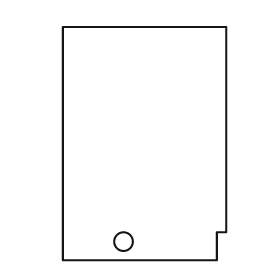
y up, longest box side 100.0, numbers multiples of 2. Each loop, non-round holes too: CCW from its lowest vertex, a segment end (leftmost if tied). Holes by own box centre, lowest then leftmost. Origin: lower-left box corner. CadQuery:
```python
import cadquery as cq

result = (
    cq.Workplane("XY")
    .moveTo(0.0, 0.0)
    .lineTo(66.0, 0.0)
    .lineTo(66.0, 12.0)
    .lineTo(70.0, 12.0)
    .lineTo(70.0, 100.0)
    .lineTo(0.0, 100.0)
    .close()
    .moveTo(26.0, 8.0)
    .circle(4.0)
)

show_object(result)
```